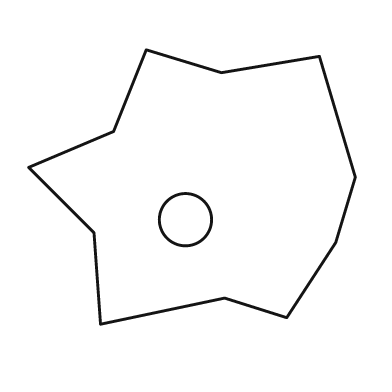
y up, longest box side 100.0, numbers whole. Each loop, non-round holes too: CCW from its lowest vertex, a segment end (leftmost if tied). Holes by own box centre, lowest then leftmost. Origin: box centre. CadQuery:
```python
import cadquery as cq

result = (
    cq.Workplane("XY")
    .moveTo(-28.0, -42.0)
    .lineTo(10.0, -34.0)
    .lineTo(29.0, -40.0)
    .lineTo(44.0, -17.0)
    .lineTo(50.0, 3.0)
    .lineTo(39.0, 40.0)
    .lineTo(9.0, 35.0)
    .lineTo(-14.0, 42.0)
    .lineTo(-24.0, 17.0)
    .lineTo(-50.0, 6.0)
    .lineTo(-30.0, -14.0)
    .close()
    .moveTo(-2.0, -10.0)
    .circle(8.0)
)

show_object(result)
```